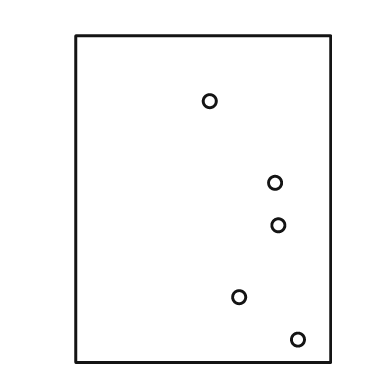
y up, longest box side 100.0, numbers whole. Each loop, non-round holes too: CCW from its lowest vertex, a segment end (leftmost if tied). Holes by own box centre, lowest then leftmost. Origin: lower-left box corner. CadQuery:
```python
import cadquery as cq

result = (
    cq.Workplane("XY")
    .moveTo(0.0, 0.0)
    .lineTo(78.0, 0.0)
    .lineTo(78.0, 100.0)
    .lineTo(0.0, 100.0)
    .close()
    .moveTo(68.0, 7.0)
    .circle(2.0)
    .moveTo(50.0, 20.0)
    .circle(2.0)
    .moveTo(62.0, 42.0)
    .circle(2.0)
    .moveTo(61.0, 55.0)
    .circle(2.0)
    .moveTo(41.0, 80.0)
    .circle(2.0)
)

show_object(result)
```